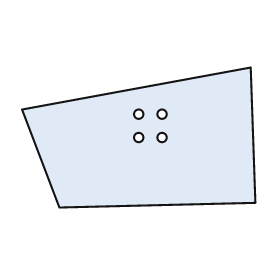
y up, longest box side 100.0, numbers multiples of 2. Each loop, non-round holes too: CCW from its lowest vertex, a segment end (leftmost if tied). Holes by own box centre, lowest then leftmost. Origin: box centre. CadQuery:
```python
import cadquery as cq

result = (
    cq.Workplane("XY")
    .moveTo(-34.0, -30.0)
    .lineTo(50.0, -28.0)
    .lineTo(48.0, 30.0)
    .lineTo(-50.0, 12.0)
    .close()
    .moveTo(0.0, 0.0)
    .circle(2.0)
    .moveTo(10.0, 0.0)
    .circle(2.0)
    .moveTo(0.0, 10.0)
    .circle(2.0)
    .moveTo(10.0, 10.0)
    .circle(2.0)
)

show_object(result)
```